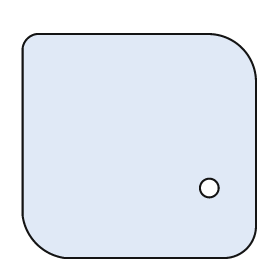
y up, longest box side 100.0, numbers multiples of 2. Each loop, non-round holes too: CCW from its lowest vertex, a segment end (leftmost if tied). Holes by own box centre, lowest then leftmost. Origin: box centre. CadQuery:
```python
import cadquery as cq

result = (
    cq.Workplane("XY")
    .moveTo(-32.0, -48.0)
    .lineTo(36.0, -48.0)
    .threePointArc((46.0, -44.0), (50.0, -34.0))
    .lineTo(50.0, 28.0)
    .threePointArc((44.0, 42.0), (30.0, 48.0))
    .lineTo(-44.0, 48.0)
    .threePointArc((-48.0, 46.0), (-50.0, 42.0))
    .lineTo(-50.0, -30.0)
    .threePointArc((-44.0, -42.0), (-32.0, -48.0))
    .close()
    .moveTo(30.0, -18.0)
    .circle(4.0)
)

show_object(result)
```